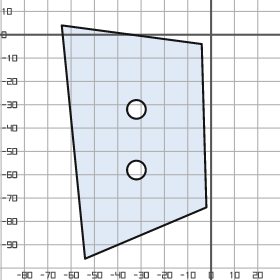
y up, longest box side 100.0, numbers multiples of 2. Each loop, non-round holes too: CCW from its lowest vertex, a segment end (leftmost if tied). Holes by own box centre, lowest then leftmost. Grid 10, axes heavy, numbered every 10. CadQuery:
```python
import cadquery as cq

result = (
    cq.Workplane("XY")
    .moveTo(-54.0, -96.0)
    .lineTo(-2.0, -74.0)
    .lineTo(-4.0, -4.0)
    .lineTo(-64.0, 4.0)
    .close()
    .moveTo(-32.0, -58.0)
    .circle(4.0)
    .moveTo(-32.0, -32.0)
    .circle(4.0)
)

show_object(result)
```